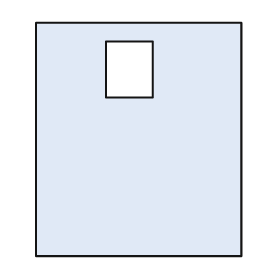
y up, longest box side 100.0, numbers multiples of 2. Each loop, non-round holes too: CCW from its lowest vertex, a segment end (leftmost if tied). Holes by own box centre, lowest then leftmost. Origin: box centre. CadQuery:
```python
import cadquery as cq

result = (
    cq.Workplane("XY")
    .moveTo(-44.0, -50.0)
    .lineTo(44.0, -50.0)
    .lineTo(44.0, 50.0)
    .lineTo(-44.0, 50.0)
    .close()
    .moveTo(-14.0, 18.0)
    .lineTo(6.0, 18.0)
    .lineTo(6.0, 42.0)
    .lineTo(-14.0, 42.0)
    .close()
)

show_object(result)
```